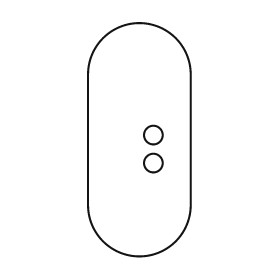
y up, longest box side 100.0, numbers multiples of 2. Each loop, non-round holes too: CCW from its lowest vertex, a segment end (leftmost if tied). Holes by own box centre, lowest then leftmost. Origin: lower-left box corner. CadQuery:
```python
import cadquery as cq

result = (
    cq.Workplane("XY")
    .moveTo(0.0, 22.0)
    .threePointArc((22.0, 0.0), (44.0, 22.0))
    .lineTo(44.0, 78.0)
    .threePointArc((22.0, 100.0), (0.0, 78.0))
    .close()
    .moveTo(28.0, 40.0)
    .circle(4.0)
    .moveTo(28.0, 52.0)
    .circle(4.0)
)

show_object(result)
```